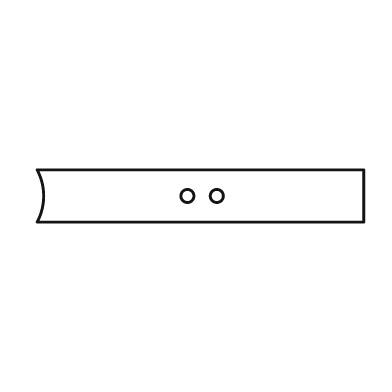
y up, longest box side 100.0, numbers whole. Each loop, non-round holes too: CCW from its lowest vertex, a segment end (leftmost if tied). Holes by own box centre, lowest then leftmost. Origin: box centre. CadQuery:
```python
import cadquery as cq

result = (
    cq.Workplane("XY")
    .moveTo(-50.0, -8.0)
    .lineTo(50.0, -8.0)
    .lineTo(50.0, 8.0)
    .lineTo(-50.0, 8.0)
    .threePointArc((-48.0, 0.0), (-50.0, -8.0))
    .close()
    .moveTo(-4.0, 0.0)
    .circle(2.0)
    .moveTo(5.0, 0.0)
    .circle(2.0)
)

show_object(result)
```